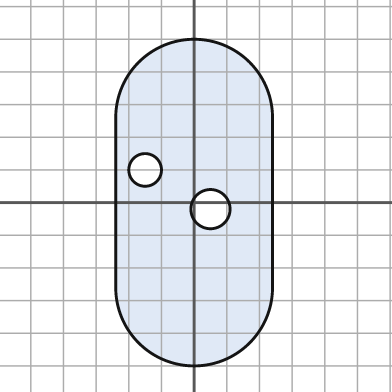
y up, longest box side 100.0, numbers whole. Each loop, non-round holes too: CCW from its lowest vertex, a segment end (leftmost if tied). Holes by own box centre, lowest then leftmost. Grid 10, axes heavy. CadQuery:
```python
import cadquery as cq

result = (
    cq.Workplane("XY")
    .moveTo(-24.0, -26.0)
    .threePointArc((0.0, -50.0), (24.0, -26.0))
    .lineTo(24.0, 26.0)
    .threePointArc((0.0, 50.0), (-24.0, 26.0))
    .close()
    .moveTo(5.0, -2.0)
    .circle(6.0)
    .moveTo(-15.0, 10.0)
    .circle(5.0)
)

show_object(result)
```